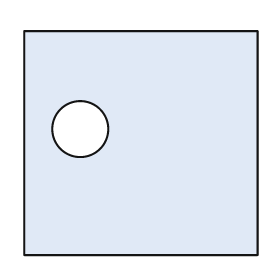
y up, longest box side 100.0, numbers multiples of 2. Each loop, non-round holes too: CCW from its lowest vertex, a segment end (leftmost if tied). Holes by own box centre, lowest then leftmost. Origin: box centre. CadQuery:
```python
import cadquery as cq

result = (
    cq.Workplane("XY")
    .moveTo(-50.0, -48.0)
    .lineTo(50.0, -48.0)
    .lineTo(50.0, 48.0)
    .lineTo(-50.0, 48.0)
    .close()
    .moveTo(-26.0, 6.0)
    .circle(12.0)
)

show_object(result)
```